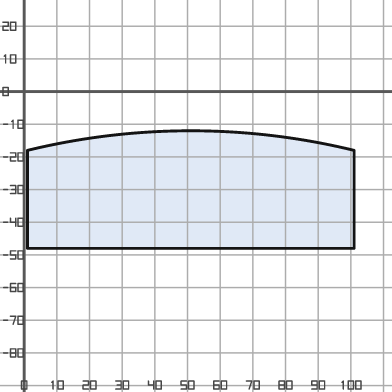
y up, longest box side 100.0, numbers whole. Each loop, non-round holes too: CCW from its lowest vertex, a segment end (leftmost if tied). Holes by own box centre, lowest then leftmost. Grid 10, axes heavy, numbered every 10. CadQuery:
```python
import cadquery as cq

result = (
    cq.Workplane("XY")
    .moveTo(1.0, -48.0)
    .lineTo(101.0, -48.0)
    .lineTo(101.0, -18.0)
    .threePointArc((51.0, -12.0), (1.0, -18.0))
    .close()
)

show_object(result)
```